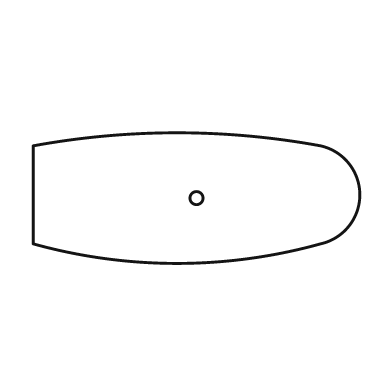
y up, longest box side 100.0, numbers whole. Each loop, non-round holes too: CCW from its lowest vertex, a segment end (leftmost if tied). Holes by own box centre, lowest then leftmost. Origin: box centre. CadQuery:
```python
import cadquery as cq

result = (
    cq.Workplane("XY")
    .moveTo(-50.0, -14.0)
    .threePointArc((-6.0, -20.0), (38.0, -14.0))
    .threePointArc((50.0, 1.0), (38.0, 16.0))
    .threePointArc((-6.0, 20.0), (-50.0, 16.0))
    .close()
    .moveTo(0.0, 0.0)
    .circle(2.0)
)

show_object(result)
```